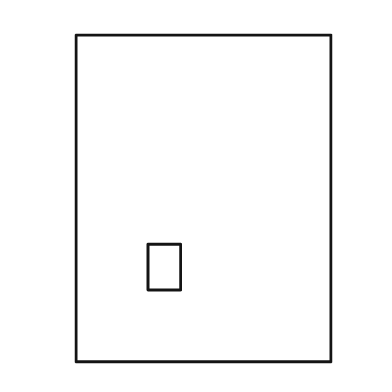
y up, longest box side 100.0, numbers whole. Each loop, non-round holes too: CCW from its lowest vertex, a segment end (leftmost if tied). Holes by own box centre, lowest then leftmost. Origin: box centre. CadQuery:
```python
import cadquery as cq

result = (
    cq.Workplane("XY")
    .moveTo(-39.0, -50.0)
    .lineTo(39.0, -50.0)
    .lineTo(39.0, 50.0)
    .lineTo(-39.0, 50.0)
    .close()
    .moveTo(-17.0, -28.0)
    .lineTo(-7.0, -28.0)
    .lineTo(-7.0, -14.0)
    .lineTo(-17.0, -14.0)
    .close()
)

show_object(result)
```